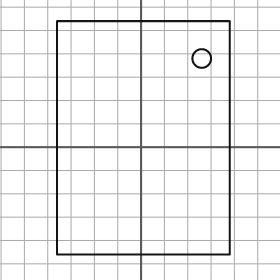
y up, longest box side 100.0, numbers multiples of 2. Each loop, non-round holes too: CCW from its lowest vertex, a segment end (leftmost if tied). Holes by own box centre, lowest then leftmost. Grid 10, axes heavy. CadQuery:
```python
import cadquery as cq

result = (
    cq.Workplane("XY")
    .moveTo(-36.0, -46.0)
    .lineTo(38.0, -46.0)
    .lineTo(38.0, 54.0)
    .lineTo(-36.0, 54.0)
    .close()
    .moveTo(26.0, 38.0)
    .circle(4.0)
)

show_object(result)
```